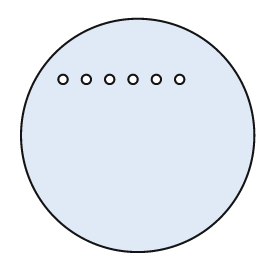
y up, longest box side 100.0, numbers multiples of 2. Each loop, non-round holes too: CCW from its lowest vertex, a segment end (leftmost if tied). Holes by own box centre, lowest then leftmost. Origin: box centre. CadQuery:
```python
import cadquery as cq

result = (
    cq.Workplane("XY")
    .moveTo(0.0, 0.0)
    .circle(50.0)
    .moveTo(-32.0, 24.0)
    .circle(2.0)
    .moveTo(-22.0, 24.0)
    .circle(2.0)
    .moveTo(-12.0, 24.0)
    .circle(2.0)
    .moveTo(-2.0, 24.0)
    .circle(2.0)
    .moveTo(8.0, 24.0)
    .circle(2.0)
    .moveTo(18.0, 24.0)
    .circle(2.0)
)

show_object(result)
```